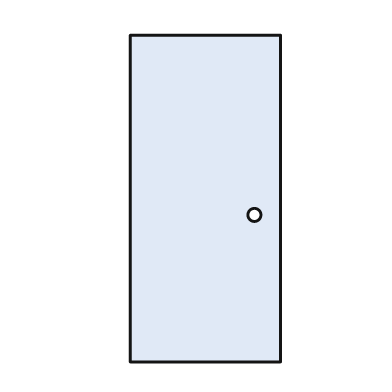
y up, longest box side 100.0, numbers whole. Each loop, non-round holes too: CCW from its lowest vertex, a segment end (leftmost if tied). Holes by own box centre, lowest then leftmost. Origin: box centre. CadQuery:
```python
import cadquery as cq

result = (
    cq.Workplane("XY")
    .moveTo(-23.0, -50.0)
    .lineTo(23.0, -50.0)
    .lineTo(23.0, 50.0)
    .lineTo(-23.0, 50.0)
    .close()
    .moveTo(15.0, -5.0)
    .circle(2.0)
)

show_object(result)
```